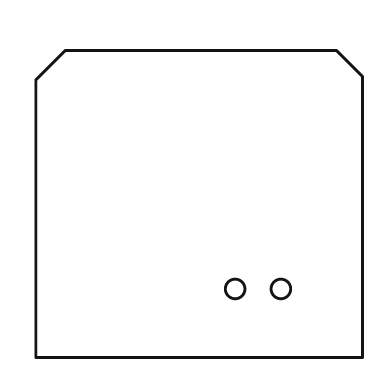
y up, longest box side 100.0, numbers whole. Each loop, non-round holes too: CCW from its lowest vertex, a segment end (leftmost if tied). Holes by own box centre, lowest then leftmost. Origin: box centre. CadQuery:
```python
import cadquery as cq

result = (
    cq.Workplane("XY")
    .moveTo(-50.0, -47.0)
    .lineTo(50.0, -47.0)
    .lineTo(50.0, 39.0)
    .lineTo(42.0, 47.0)
    .lineTo(-41.0, 47.0)
    .lineTo(-50.0, 38.0)
    .close()
    .moveTo(11.0, -26.0)
    .circle(3.0)
    .moveTo(25.0, -26.0)
    .circle(3.0)
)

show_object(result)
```